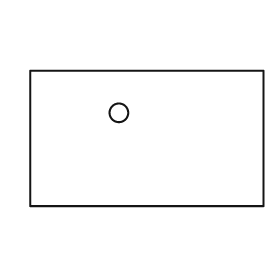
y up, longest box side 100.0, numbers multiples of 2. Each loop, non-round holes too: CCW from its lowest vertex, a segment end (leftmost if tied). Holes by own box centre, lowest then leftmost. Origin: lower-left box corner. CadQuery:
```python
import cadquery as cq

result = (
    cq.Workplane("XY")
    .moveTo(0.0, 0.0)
    .lineTo(100.0, 0.0)
    .lineTo(100.0, 58.0)
    .lineTo(0.0, 58.0)
    .close()
    .moveTo(38.0, 40.0)
    .circle(4.0)
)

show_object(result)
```